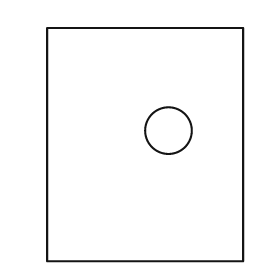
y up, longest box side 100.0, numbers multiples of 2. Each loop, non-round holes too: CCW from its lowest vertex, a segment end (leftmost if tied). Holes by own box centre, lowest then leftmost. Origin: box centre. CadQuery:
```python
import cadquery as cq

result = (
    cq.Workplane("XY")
    .moveTo(-42.0, -50.0)
    .lineTo(42.0, -50.0)
    .lineTo(42.0, 50.0)
    .lineTo(-42.0, 50.0)
    .close()
    .moveTo(10.0, 6.0)
    .circle(10.0)
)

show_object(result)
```